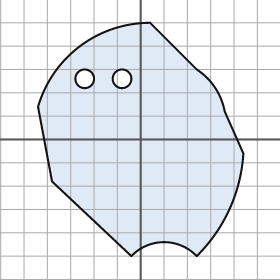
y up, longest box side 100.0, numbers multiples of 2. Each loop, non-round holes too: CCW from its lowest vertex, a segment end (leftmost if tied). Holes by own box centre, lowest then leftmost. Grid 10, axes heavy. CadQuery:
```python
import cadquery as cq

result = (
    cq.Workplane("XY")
    .moveTo(-4.0, -50.0)
    .threePointArc((10.0, -44.0), (24.0, -50.0))
    .threePointArc((38.0, -30.0), (44.0, -6.0))
    .lineTo(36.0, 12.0)
    .threePointArc((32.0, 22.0), (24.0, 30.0))
    .lineTo(4.0, 50.0)
    .threePointArc((-26.0, 40.0), (-44.0, 14.0))
    .lineTo(-38.0, -18.0)
    .close()
    .moveTo(-24.0, 26.0)
    .circle(4.0)
    .moveTo(-8.0, 26.0)
    .circle(4.0)
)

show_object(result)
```